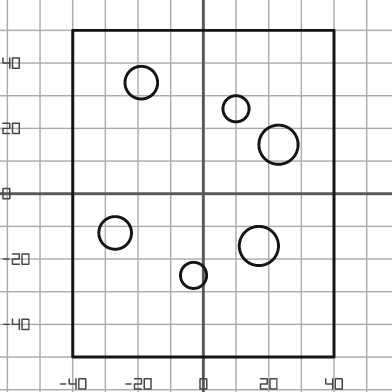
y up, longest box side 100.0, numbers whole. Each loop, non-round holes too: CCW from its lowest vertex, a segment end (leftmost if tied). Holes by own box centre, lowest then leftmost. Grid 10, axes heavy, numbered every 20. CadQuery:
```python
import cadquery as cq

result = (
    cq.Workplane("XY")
    .moveTo(-40.0, -50.0)
    .lineTo(40.0, -50.0)
    .lineTo(40.0, 50.0)
    .lineTo(-40.0, 50.0)
    .close()
    .moveTo(-3.0, -25.0)
    .circle(4.0)
    .moveTo(17.0, -16.0)
    .circle(6.0)
    .moveTo(-27.0, -12.0)
    .circle(5.0)
    .moveTo(23.0, 15.0)
    .circle(6.0)
    .moveTo(10.0, 26.0)
    .circle(4.0)
    .moveTo(-19.0, 34.0)
    .circle(5.0)
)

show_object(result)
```